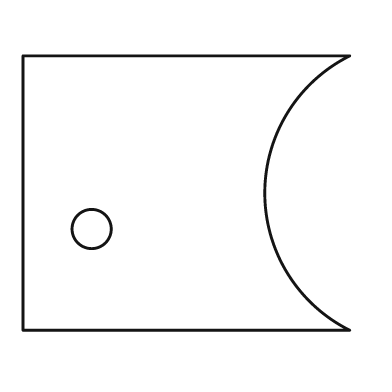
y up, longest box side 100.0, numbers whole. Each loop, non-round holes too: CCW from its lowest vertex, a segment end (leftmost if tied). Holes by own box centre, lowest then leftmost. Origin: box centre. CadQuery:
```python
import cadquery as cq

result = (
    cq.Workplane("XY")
    .moveTo(-50.0, -42.0)
    .lineTo(50.0, -42.0)
    .threePointArc((24.0, 0.0), (50.0, 42.0))
    .lineTo(-50.0, 42.0)
    .close()
    .moveTo(-29.0, -11.0)
    .circle(6.0)
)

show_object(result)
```